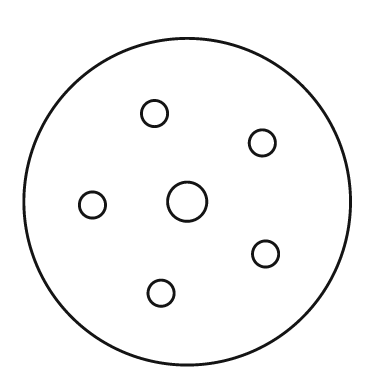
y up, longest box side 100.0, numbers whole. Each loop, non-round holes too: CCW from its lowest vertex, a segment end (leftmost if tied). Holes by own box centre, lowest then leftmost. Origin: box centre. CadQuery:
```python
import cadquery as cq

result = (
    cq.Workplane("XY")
    .moveTo(0.0, 0.0)
    .circle(50.0)
    .moveTo(-8.0, -28.0)
    .circle(4.0)
    .moveTo(24.0, -16.0)
    .circle(4.0)
    .moveTo(-29.0, -1.0)
    .circle(4.0)
    .moveTo(0.0, 0.0)
    .circle(6.0)
    .moveTo(23.0, 18.0)
    .circle(4.0)
    .moveTo(-10.0, 27.0)
    .circle(4.0)
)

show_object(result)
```